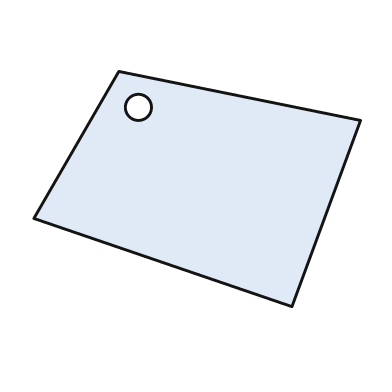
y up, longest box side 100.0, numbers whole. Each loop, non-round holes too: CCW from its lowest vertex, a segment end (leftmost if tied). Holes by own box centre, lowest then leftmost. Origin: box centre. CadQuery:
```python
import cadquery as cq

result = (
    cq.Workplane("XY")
    .moveTo(29.0, -36.0)
    .lineTo(50.0, 21.0)
    .lineTo(-24.0, 36.0)
    .lineTo(-50.0, -9.0)
    .close()
    .moveTo(-18.0, 25.0)
    .circle(4.0)
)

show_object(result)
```